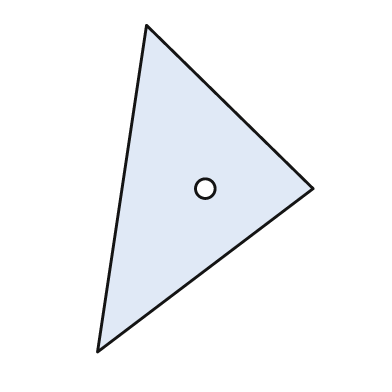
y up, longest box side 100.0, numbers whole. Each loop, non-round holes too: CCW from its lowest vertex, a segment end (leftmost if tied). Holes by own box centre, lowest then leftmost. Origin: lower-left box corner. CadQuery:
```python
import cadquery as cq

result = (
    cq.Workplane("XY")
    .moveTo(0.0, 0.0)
    .lineTo(66.0, 50.0)
    .lineTo(15.0, 100.0)
    .close()
    .moveTo(33.0, 50.0)
    .circle(3.0)
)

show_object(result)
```